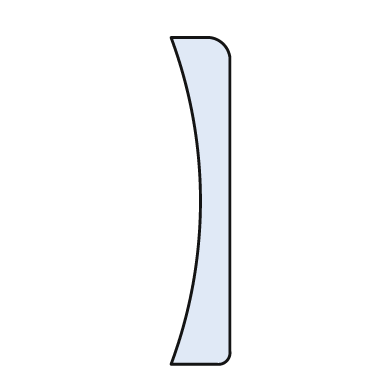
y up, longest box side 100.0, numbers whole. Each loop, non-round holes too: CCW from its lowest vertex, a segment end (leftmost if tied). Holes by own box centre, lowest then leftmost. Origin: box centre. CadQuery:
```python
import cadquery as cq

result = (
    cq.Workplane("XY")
    .moveTo(-9.0, -50.0)
    .lineTo(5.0, -50.0)
    .threePointArc((8.0, -49.0), (9.0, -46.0))
    .lineTo(9.0, 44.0)
    .threePointArc((7.0, 48.0), (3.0, 50.0))
    .lineTo(-9.0, 50.0)
    .threePointArc((0.0, 0.0), (-9.0, -50.0))
    .close()
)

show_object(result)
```